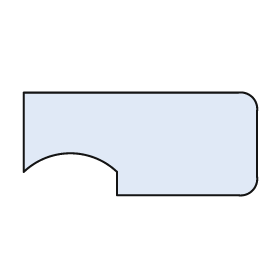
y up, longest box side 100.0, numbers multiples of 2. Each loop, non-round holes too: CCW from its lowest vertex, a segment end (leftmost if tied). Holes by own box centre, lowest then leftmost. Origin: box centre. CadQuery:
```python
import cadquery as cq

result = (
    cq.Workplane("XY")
    .moveTo(-10.0, -22.0)
    .lineTo(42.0, -22.0)
    .threePointArc((48.0, -20.0), (50.0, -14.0))
    .lineTo(50.0, 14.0)
    .threePointArc((48.0, 20.0), (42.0, 22.0))
    .lineTo(-50.0, 22.0)
    .lineTo(-50.0, -12.0)
    .threePointArc((-30.0, -4.0), (-10.0, -12.0))
    .close()
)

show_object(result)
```